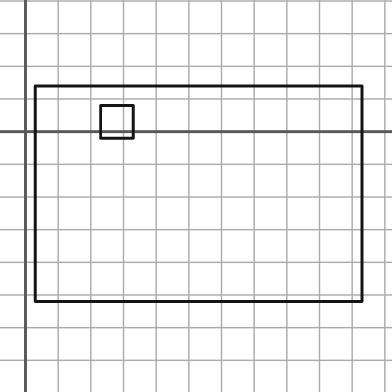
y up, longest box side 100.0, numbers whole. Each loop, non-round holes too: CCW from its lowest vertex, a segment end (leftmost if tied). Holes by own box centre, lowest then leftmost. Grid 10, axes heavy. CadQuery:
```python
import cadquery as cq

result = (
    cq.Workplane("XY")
    .moveTo(3.0, -52.0)
    .lineTo(103.0, -52.0)
    .lineTo(103.0, 14.0)
    .lineTo(3.0, 14.0)
    .close()
    .moveTo(23.0, -2.0)
    .lineTo(33.0, -2.0)
    .lineTo(33.0, 8.0)
    .lineTo(23.0, 8.0)
    .close()
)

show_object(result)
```